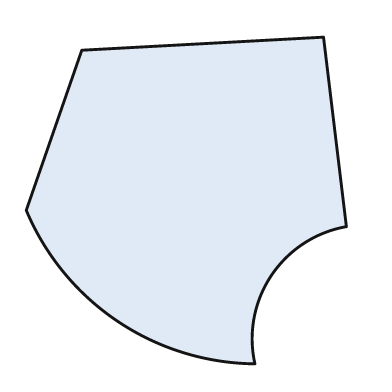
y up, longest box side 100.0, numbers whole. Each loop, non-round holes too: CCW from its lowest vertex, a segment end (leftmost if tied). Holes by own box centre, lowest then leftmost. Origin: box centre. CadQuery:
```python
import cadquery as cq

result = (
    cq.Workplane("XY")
    .moveTo(21.0, -50.0)
    .threePointArc((26.0, -23.0), (49.0, -8.0))
    .lineTo(42.0, 50.0)
    .lineTo(-32.0, 46.0)
    .lineTo(-49.0, -3.0)
    .threePointArc((-21.0, -37.0), (21.0, -50.0))
    .close()
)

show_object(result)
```